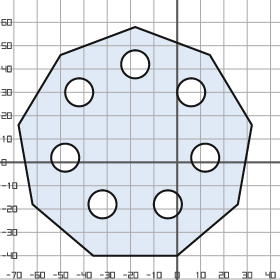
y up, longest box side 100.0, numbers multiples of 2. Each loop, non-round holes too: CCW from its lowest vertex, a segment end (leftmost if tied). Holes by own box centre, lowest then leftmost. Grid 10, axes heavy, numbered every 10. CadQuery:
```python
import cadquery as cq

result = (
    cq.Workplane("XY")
    .moveTo(-36.0, -40.0)
    .lineTo(0.0, -40.0)
    .lineTo(26.0, -18.0)
    .lineTo(32.0, 16.0)
    .lineTo(14.0, 46.0)
    .lineTo(-18.0, 58.0)
    .lineTo(-50.0, 46.0)
    .lineTo(-68.0, 16.0)
    .lineTo(-62.0, -18.0)
    .close()
    .moveTo(-32.0, -18.0)
    .circle(6.0)
    .moveTo(-4.0, -18.0)
    .circle(6.0)
    .moveTo(-48.0, 2.0)
    .circle(6.0)
    .moveTo(12.0, 2.0)
    .circle(6.0)
    .moveTo(-42.0, 30.0)
    .circle(6.0)
    .moveTo(6.0, 30.0)
    .circle(6.0)
    .moveTo(-18.0, 42.0)
    .circle(6.0)
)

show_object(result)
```